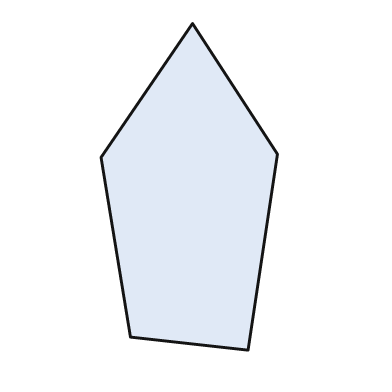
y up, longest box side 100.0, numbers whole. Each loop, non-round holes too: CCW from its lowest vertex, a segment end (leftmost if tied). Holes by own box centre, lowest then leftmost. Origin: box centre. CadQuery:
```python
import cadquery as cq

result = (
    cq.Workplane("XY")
    .moveTo(18.0, -50.0)
    .lineTo(27.0, 10.0)
    .lineTo(1.0, 50.0)
    .lineTo(-27.0, 9.0)
    .lineTo(-18.0, -46.0)
    .close()
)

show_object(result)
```